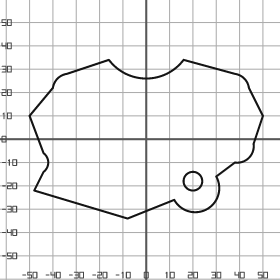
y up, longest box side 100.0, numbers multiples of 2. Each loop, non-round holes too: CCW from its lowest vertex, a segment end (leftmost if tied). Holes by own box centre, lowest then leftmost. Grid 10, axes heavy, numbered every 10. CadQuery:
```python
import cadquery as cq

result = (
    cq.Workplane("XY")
    .moveTo(-8.0, -34.0)
    .lineTo(12.0, -26.0)
    .threePointArc((26.0, -30.0), (30.0, -16.0))
    .lineTo(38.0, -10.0)
    .threePointArc((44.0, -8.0), (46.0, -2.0))
    .lineTo(50.0, 10.0)
    .lineTo(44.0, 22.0)
    .threePointArc((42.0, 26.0), (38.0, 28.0))
    .lineTo(16.0, 34.0)
    .threePointArc((0.0, 26.0), (-16.0, 34.0))
    .lineTo(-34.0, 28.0)
    .threePointArc((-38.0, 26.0), (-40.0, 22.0))
    .lineTo(-50.0, 10.0)
    .lineTo(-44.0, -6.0)
    .threePointArc((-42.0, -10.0), (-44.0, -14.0))
    .lineTo(-48.0, -22.0)
    .close()
    .moveTo(20.0, -18.0)
    .circle(4.0)
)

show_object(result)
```